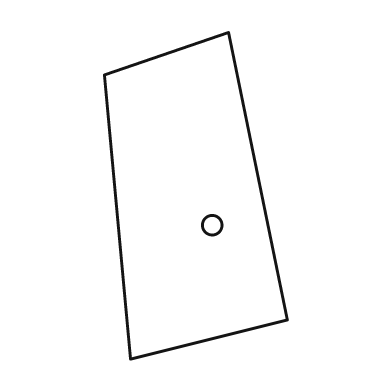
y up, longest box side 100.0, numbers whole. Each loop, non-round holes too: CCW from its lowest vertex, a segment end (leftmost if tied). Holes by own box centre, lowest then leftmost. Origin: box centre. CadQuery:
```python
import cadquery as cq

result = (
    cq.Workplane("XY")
    .moveTo(-20.0, -50.0)
    .lineTo(28.0, -38.0)
    .lineTo(10.0, 50.0)
    .lineTo(-28.0, 37.0)
    .close()
    .moveTo(5.0, -9.0)
    .circle(3.0)
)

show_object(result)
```